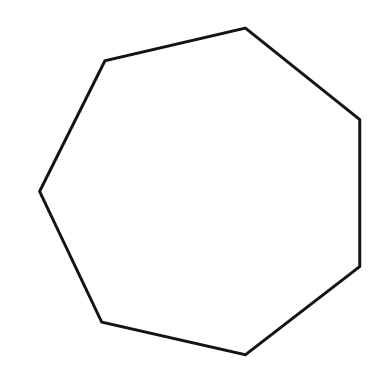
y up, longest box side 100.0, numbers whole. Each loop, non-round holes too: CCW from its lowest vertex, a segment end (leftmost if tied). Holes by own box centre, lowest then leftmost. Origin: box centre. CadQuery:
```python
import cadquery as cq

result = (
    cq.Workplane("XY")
    .moveTo(14.0, -50.0)
    .lineTo(49.0, -23.0)
    .lineTo(49.0, 22.0)
    .lineTo(14.0, 50.0)
    .lineTo(-29.0, 40.0)
    .lineTo(-49.0, 0.0)
    .lineTo(-30.0, -40.0)
    .close()
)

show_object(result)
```